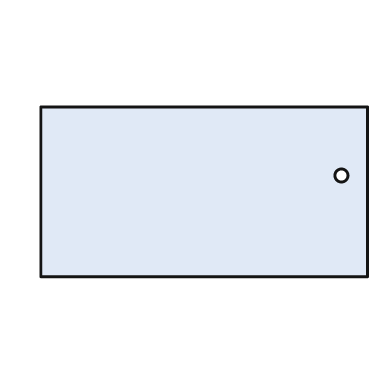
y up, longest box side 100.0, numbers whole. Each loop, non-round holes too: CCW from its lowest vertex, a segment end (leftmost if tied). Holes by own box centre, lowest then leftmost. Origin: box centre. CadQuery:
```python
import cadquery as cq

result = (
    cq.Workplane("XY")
    .moveTo(-50.0, -26.0)
    .lineTo(50.0, -26.0)
    .lineTo(50.0, 26.0)
    .lineTo(-50.0, 26.0)
    .close()
    .moveTo(42.0, 5.0)
    .circle(2.0)
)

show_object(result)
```